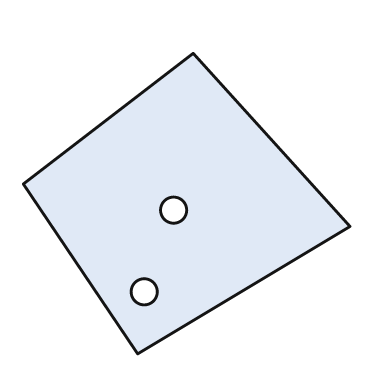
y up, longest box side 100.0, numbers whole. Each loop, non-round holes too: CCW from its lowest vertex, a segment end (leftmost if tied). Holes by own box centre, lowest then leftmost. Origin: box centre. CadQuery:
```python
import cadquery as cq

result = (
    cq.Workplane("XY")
    .moveTo(-15.0, -46.0)
    .lineTo(50.0, -7.0)
    .lineTo(2.0, 46.0)
    .lineTo(-50.0, 6.0)
    .close()
    .moveTo(-13.0, -27.0)
    .circle(4.0)
    .moveTo(-4.0, -2.0)
    .circle(4.0)
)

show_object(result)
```